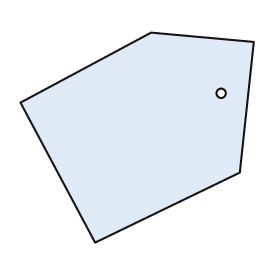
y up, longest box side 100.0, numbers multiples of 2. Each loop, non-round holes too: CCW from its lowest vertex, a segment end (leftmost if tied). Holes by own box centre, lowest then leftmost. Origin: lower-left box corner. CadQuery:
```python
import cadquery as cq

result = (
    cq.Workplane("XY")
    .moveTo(32.0, 0.0)
    .lineTo(94.0, 30.0)
    .lineTo(100.0, 86.0)
    .lineTo(56.0, 90.0)
    .lineTo(0.0, 60.0)
    .close()
    .moveTo(86.0, 64.0)
    .circle(2.0)
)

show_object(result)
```